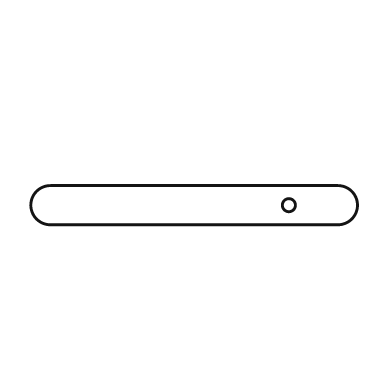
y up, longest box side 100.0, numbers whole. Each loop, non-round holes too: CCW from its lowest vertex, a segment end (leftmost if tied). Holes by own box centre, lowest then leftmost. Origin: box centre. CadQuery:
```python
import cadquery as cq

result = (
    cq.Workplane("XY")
    .moveTo(-44.0, -6.0)
    .lineTo(44.0, -6.0)
    .threePointArc((50.0, 0.0), (44.0, 6.0))
    .lineTo(-44.0, 6.0)
    .threePointArc((-50.0, 0.0), (-44.0, -6.0))
    .close()
    .moveTo(29.0, 0.0)
    .circle(2.0)
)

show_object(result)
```